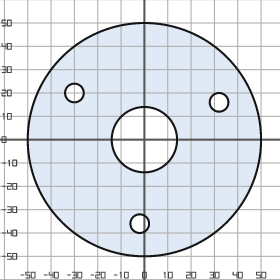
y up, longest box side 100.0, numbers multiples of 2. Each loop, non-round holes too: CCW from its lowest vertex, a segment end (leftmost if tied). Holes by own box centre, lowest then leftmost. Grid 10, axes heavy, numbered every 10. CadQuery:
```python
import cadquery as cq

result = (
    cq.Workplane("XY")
    .moveTo(0.0, 0.0)
    .circle(50.0)
    .moveTo(-2.0, -36.0)
    .circle(4.0)
    .moveTo(0.0, 0.0)
    .circle(14.0)
    .moveTo(32.0, 16.0)
    .circle(4.0)
    .moveTo(-30.0, 20.0)
    .circle(4.0)
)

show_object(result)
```